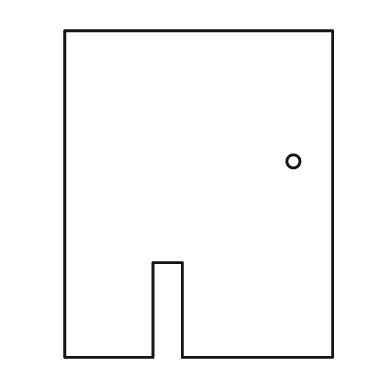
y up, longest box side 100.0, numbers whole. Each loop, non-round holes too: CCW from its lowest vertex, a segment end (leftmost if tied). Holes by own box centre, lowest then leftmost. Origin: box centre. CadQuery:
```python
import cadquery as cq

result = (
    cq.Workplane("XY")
    .moveTo(-41.0, -50.0)
    .lineTo(-14.0, -50.0)
    .lineTo(-14.0, -21.0)
    .lineTo(-5.0, -21.0)
    .lineTo(-5.0, -50.0)
    .lineTo(41.0, -50.0)
    .lineTo(41.0, 50.0)
    .lineTo(-41.0, 50.0)
    .close()
    .moveTo(29.0, 10.0)
    .circle(2.0)
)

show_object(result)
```